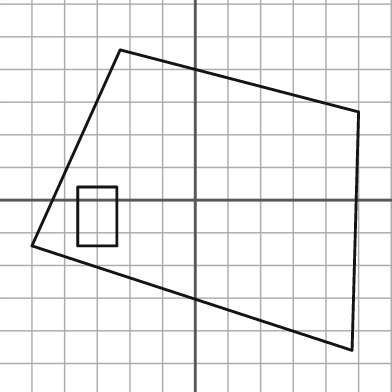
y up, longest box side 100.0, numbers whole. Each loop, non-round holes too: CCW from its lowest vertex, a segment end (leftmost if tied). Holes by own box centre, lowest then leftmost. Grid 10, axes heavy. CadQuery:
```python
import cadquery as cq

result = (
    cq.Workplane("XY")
    .moveTo(48.0, -46.0)
    .lineTo(50.0, 27.0)
    .lineTo(-23.0, 46.0)
    .lineTo(-50.0, -14.0)
    .close()
    .moveTo(-36.0, -14.0)
    .lineTo(-24.0, -14.0)
    .lineTo(-24.0, 4.0)
    .lineTo(-36.0, 4.0)
    .close()
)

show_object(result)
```